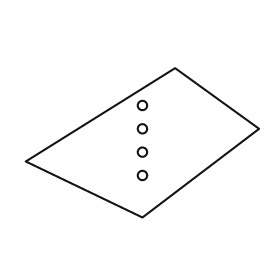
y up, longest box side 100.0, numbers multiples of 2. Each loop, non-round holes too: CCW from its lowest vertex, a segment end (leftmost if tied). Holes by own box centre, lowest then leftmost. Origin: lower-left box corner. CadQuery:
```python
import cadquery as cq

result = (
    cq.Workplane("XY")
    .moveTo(50.0, 0.0)
    .lineTo(100.0, 38.0)
    .lineTo(64.0, 64.0)
    .lineTo(0.0, 24.0)
    .close()
    .moveTo(50.0, 18.0)
    .circle(2.0)
    .moveTo(50.0, 28.0)
    .circle(2.0)
    .moveTo(50.0, 38.0)
    .circle(2.0)
    .moveTo(50.0, 48.0)
    .circle(2.0)
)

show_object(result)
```